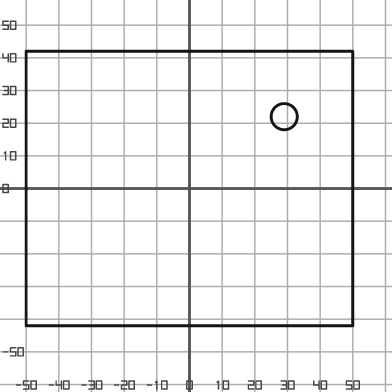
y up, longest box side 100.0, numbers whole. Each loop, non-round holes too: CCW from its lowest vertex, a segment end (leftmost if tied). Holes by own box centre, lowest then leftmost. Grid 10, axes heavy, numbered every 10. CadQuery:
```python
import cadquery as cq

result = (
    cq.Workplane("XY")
    .moveTo(-50.0, -42.0)
    .lineTo(50.0, -42.0)
    .lineTo(50.0, 42.0)
    .lineTo(-50.0, 42.0)
    .close()
    .moveTo(29.0, 22.0)
    .circle(4.0)
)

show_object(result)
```